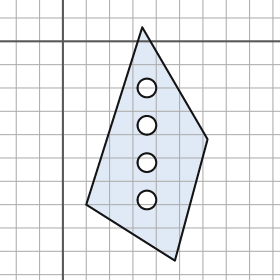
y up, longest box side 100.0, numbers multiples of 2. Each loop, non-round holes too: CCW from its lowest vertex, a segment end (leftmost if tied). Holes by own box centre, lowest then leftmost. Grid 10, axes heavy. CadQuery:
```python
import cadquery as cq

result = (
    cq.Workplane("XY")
    .moveTo(48.0, -94.0)
    .lineTo(62.0, -42.0)
    .lineTo(34.0, 6.0)
    .lineTo(10.0, -70.0)
    .close()
    .moveTo(36.0, -68.0)
    .circle(4.0)
    .moveTo(36.0, -52.0)
    .circle(4.0)
    .moveTo(36.0, -36.0)
    .circle(4.0)
    .moveTo(36.0, -20.0)
    .circle(4.0)
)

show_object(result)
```